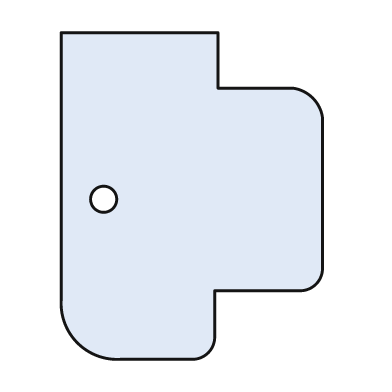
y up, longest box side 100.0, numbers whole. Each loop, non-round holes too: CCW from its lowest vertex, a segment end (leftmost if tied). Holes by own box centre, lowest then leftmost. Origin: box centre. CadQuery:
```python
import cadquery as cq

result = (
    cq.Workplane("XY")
    .moveTo(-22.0, -50.0)
    .lineTo(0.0, -50.0)
    .threePointArc((5.0, -48.0), (7.0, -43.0))
    .lineTo(7.0, -29.0)
    .lineTo(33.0, -29.0)
    .threePointArc((38.0, -27.0), (40.0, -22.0))
    .lineTo(40.0, 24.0)
    .threePointArc((37.0, 30.0), (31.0, 33.0))
    .lineTo(8.0, 33.0)
    .lineTo(8.0, 50.0)
    .lineTo(-40.0, 50.0)
    .lineTo(-40.0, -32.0)
    .threePointArc((-35.0, -45.0), (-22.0, -50.0))
    .close()
    .moveTo(-27.0, -1.0)
    .circle(4.0)
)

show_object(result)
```